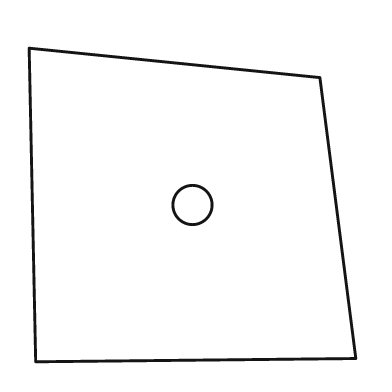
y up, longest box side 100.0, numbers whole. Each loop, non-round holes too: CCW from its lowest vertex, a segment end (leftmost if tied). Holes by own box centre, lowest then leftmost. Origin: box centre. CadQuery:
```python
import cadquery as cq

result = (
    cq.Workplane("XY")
    .moveTo(-48.0, -48.0)
    .lineTo(50.0, -47.0)
    .lineTo(39.0, 39.0)
    .lineTo(-50.0, 48.0)
    .close()
    .moveTo(0.0, 0.0)
    .circle(6.0)
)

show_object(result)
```